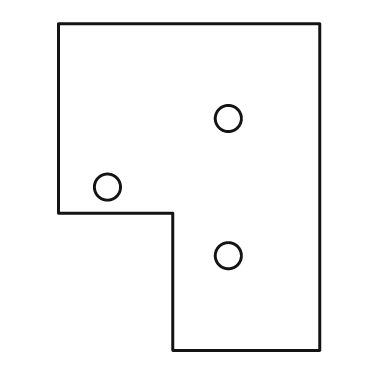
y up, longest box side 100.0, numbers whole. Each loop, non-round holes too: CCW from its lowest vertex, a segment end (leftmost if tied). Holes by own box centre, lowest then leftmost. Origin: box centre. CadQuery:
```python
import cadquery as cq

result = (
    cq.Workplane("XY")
    .moveTo(-5.0, -50.0)
    .lineTo(40.0, -50.0)
    .lineTo(40.0, 50.0)
    .lineTo(-40.0, 50.0)
    .lineTo(-40.0, -8.0)
    .lineTo(-5.0, -8.0)
    .close()
    .moveTo(12.0, -21.0)
    .circle(4.0)
    .moveTo(-25.0, 0.0)
    .circle(4.0)
    .moveTo(12.0, 21.0)
    .circle(4.0)
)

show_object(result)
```